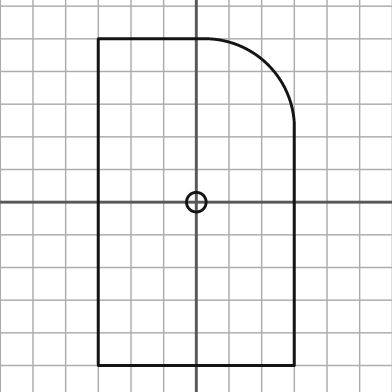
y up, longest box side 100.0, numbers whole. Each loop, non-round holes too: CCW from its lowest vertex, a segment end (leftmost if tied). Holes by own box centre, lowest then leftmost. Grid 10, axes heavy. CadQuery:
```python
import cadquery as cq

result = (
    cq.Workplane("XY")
    .moveTo(-30.0, -50.0)
    .lineTo(30.0, -50.0)
    .lineTo(30.0, 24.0)
    .threePointArc((22.0, 42.0), (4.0, 50.0))
    .lineTo(-30.0, 50.0)
    .close()
    .moveTo(0.0, 0.0)
    .circle(3.0)
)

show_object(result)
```